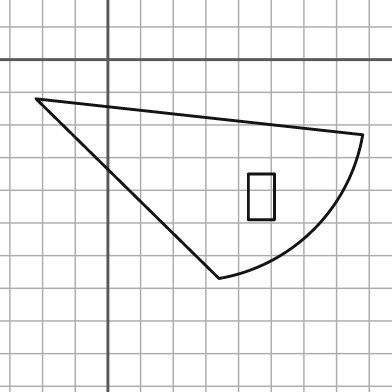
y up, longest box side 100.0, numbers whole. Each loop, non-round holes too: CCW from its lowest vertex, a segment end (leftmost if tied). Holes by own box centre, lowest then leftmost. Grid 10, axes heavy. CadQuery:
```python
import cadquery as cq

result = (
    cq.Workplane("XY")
    .moveTo(34.0, -67.0)
    .threePointArc((63.0, -52.0), (78.0, -23.0))
    .lineTo(-22.0, -12.0)
    .close()
    .moveTo(43.0, -49.0)
    .lineTo(51.0, -49.0)
    .lineTo(51.0, -35.0)
    .lineTo(43.0, -35.0)
    .close()
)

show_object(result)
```